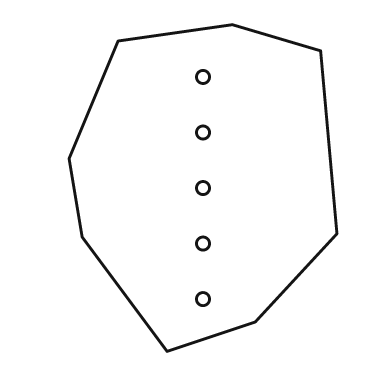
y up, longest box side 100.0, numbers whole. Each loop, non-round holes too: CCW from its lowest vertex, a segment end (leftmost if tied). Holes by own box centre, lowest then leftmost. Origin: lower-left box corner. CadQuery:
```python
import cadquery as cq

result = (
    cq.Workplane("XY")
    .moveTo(30.0, 0.0)
    .lineTo(57.0, 9.0)
    .lineTo(82.0, 36.0)
    .lineTo(77.0, 92.0)
    .lineTo(50.0, 100.0)
    .lineTo(15.0, 95.0)
    .lineTo(0.0, 59.0)
    .lineTo(4.0, 35.0)
    .close()
    .moveTo(41.0, 16.0)
    .circle(2.0)
    .moveTo(41.0, 33.0)
    .circle(2.0)
    .moveTo(41.0, 50.0)
    .circle(2.0)
    .moveTo(41.0, 67.0)
    .circle(2.0)
    .moveTo(41.0, 84.0)
    .circle(2.0)
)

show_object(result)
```